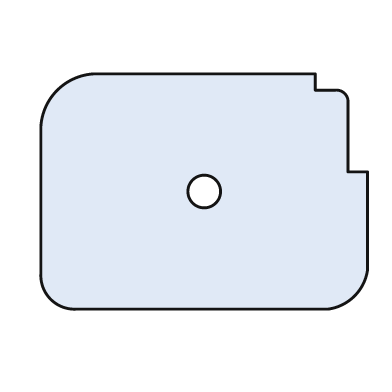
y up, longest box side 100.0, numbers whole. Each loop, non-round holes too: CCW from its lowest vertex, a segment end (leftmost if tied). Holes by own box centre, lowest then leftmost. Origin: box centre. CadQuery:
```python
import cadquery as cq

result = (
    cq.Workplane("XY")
    .moveTo(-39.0, -36.0)
    .lineTo(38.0, -36.0)
    .threePointArc((46.0, -32.0), (50.0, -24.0))
    .lineTo(50.0, 6.0)
    .lineTo(44.0, 6.0)
    .lineTo(44.0, 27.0)
    .threePointArc((43.0, 30.0), (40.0, 31.0))
    .lineTo(34.0, 31.0)
    .lineTo(34.0, 36.0)
    .lineTo(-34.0, 36.0)
    .threePointArc((-45.0, 31.0), (-50.0, 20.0))
    .lineTo(-50.0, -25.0)
    .threePointArc((-47.0, -33.0), (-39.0, -36.0))
    .close()
    .moveTo(0.0, 0.0)
    .circle(5.0)
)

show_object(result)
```